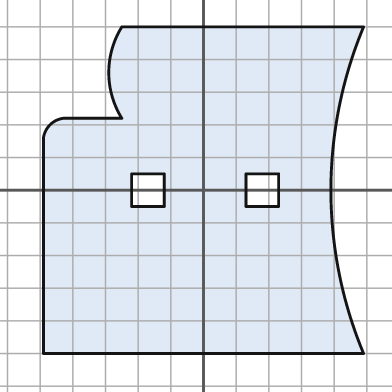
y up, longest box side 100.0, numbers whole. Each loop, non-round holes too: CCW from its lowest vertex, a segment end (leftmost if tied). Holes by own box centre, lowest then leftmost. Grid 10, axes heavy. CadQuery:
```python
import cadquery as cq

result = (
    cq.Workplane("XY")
    .moveTo(-49.0, -50.0)
    .lineTo(49.0, -50.0)
    .threePointArc((39.0, 0.0), (49.0, 50.0))
    .lineTo(-25.0, 50.0)
    .threePointArc((-29.0, 36.0), (-25.0, 22.0))
    .lineTo(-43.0, 22.0)
    .threePointArc((-47.0, 20.0), (-49.0, 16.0))
    .close()
    .moveTo(-22.0, -5.0)
    .lineTo(-12.0, -5.0)
    .lineTo(-12.0, 5.0)
    .lineTo(-22.0, 5.0)
    .close()
    .moveTo(13.0, -5.0)
    .lineTo(23.0, -5.0)
    .lineTo(23.0, 5.0)
    .lineTo(13.0, 5.0)
    .close()
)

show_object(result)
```